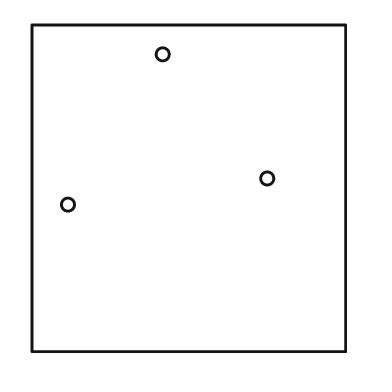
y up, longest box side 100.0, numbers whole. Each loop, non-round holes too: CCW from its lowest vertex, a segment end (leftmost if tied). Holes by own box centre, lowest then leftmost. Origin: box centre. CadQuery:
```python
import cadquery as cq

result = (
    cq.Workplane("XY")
    .moveTo(-48.0, -50.0)
    .lineTo(48.0, -50.0)
    .lineTo(48.0, 50.0)
    .lineTo(-48.0, 50.0)
    .close()
    .moveTo(-37.0, -5.0)
    .circle(2.0)
    .moveTo(24.0, 3.0)
    .circle(2.0)
    .moveTo(-8.0, 41.0)
    .circle(2.0)
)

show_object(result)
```